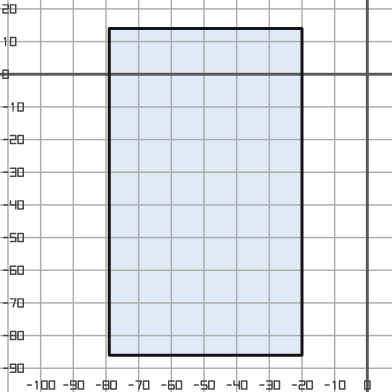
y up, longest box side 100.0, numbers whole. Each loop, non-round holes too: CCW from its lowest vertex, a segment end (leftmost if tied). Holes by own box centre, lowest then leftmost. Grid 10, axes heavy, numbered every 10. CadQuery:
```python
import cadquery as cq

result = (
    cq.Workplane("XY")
    .moveTo(-79.0, -86.0)
    .lineTo(-20.0, -86.0)
    .lineTo(-20.0, 14.0)
    .lineTo(-79.0, 14.0)
    .close()
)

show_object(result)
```